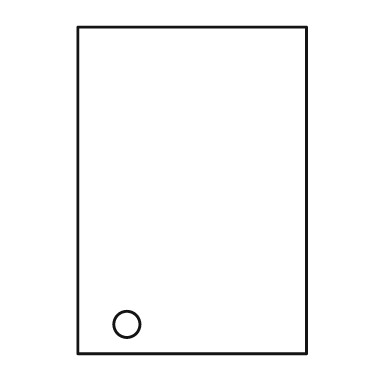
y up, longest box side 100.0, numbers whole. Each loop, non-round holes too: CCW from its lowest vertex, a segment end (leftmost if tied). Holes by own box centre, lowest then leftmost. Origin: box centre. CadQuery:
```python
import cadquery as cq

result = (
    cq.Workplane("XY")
    .moveTo(-35.0, -50.0)
    .lineTo(35.0, -50.0)
    .lineTo(35.0, 50.0)
    .lineTo(-35.0, 50.0)
    .close()
    .moveTo(-20.0, -41.0)
    .circle(4.0)
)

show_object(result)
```